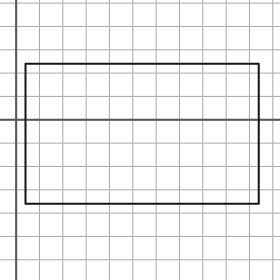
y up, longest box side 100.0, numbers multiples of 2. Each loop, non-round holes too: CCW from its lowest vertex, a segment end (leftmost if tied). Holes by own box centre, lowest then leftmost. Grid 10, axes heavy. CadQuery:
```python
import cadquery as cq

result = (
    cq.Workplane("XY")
    .moveTo(4.0, -36.0)
    .lineTo(104.0, -36.0)
    .lineTo(104.0, 24.0)
    .lineTo(4.0, 24.0)
    .close()
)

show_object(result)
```